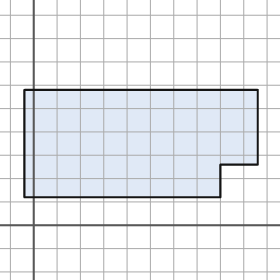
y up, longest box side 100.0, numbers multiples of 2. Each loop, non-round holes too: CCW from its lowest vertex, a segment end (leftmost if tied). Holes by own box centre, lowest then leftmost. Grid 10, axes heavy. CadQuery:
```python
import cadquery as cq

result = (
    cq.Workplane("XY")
    .moveTo(-4.0, 12.0)
    .lineTo(80.0, 12.0)
    .lineTo(80.0, 26.0)
    .lineTo(96.0, 26.0)
    .lineTo(96.0, 58.0)
    .lineTo(-4.0, 58.0)
    .close()
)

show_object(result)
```